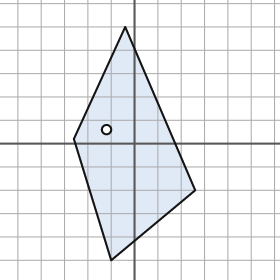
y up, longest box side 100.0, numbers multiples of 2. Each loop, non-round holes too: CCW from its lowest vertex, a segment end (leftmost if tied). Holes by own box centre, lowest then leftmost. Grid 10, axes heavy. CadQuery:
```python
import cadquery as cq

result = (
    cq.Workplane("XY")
    .moveTo(-10.0, -50.0)
    .lineTo(26.0, -20.0)
    .lineTo(-4.0, 50.0)
    .lineTo(-26.0, 2.0)
    .close()
    .moveTo(-12.0, 6.0)
    .circle(2.0)
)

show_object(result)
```